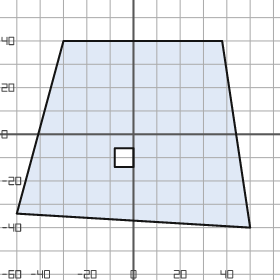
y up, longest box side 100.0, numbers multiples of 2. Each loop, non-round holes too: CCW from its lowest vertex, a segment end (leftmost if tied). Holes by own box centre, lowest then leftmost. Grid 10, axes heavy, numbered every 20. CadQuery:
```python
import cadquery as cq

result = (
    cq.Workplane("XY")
    .moveTo(50.0, -40.0)
    .lineTo(38.0, 40.0)
    .lineTo(-30.0, 40.0)
    .lineTo(-50.0, -34.0)
    .close()
    .moveTo(-8.0, -14.0)
    .lineTo(0.0, -14.0)
    .lineTo(0.0, -6.0)
    .lineTo(-8.0, -6.0)
    .close()
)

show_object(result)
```